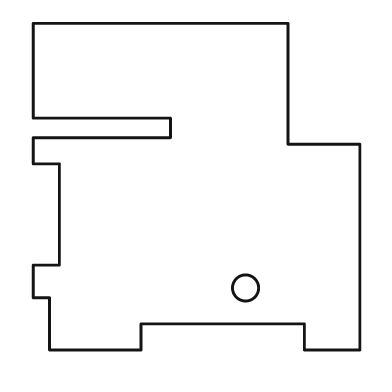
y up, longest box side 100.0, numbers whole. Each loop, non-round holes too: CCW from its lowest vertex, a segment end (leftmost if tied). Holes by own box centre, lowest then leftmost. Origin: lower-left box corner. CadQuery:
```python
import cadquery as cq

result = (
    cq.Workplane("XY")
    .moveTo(5.0, 0.0)
    .lineTo(33.0, 0.0)
    .lineTo(33.0, 8.0)
    .lineTo(83.0, 8.0)
    .lineTo(83.0, 0.0)
    .lineTo(100.0, 0.0)
    .lineTo(100.0, 63.0)
    .lineTo(78.0, 63.0)
    .lineTo(78.0, 100.0)
    .lineTo(0.0, 100.0)
    .lineTo(0.0, 71.0)
    .lineTo(42.0, 71.0)
    .lineTo(42.0, 65.0)
    .lineTo(0.0, 65.0)
    .lineTo(0.0, 57.0)
    .lineTo(8.0, 57.0)
    .lineTo(8.0, 26.0)
    .lineTo(0.0, 26.0)
    .lineTo(0.0, 16.0)
    .lineTo(5.0, 16.0)
    .close()
    .moveTo(65.0, 19.0)
    .circle(4.0)
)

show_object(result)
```